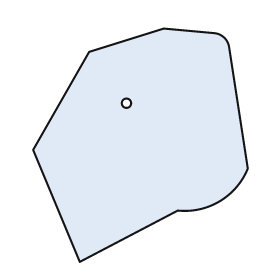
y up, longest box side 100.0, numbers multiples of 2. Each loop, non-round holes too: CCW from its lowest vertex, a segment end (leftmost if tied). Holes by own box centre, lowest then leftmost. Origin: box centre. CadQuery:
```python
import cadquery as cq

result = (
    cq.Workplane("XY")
    .moveTo(-26.0, -50.0)
    .lineTo(16.0, -28.0)
    .threePointArc((34.0, -24.0), (46.0, -10.0))
    .lineTo(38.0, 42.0)
    .threePointArc((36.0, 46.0), (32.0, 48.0))
    .lineTo(10.0, 50.0)
    .lineTo(-22.0, 40.0)
    .lineTo(-46.0, -2.0)
    .close()
    .moveTo(-6.0, 18.0)
    .circle(2.0)
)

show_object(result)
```